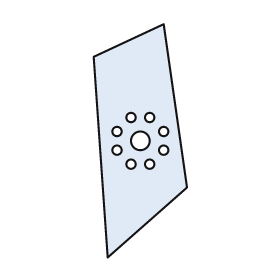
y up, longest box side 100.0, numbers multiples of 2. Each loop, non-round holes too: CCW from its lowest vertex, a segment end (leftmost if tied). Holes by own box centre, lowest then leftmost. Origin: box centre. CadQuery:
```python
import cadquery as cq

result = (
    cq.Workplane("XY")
    .moveTo(-14.0, -50.0)
    .lineTo(20.0, -20.0)
    .lineTo(10.0, 50.0)
    .lineTo(-20.0, 36.0)
    .close()
    .moveTo(-4.0, -10.0)
    .circle(2.0)
    .moveTo(4.0, -10.0)
    .circle(2.0)
    .moveTo(-10.0, -4.0)
    .circle(2.0)
    .moveTo(10.0, -4.0)
    .circle(2.0)
    .moveTo(0.0, 0.0)
    .circle(4.0)
    .moveTo(-10.0, 4.0)
    .circle(2.0)
    .moveTo(10.0, 4.0)
    .circle(2.0)
    .moveTo(-4.0, 10.0)
    .circle(2.0)
    .moveTo(4.0, 10.0)
    .circle(2.0)
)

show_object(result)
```